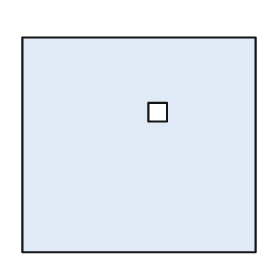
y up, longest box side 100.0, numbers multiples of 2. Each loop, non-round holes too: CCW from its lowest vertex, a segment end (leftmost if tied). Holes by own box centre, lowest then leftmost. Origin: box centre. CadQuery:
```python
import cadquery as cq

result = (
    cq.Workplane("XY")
    .moveTo(-50.0, -46.0)
    .lineTo(50.0, -46.0)
    .lineTo(50.0, 46.0)
    .lineTo(-50.0, 46.0)
    .close()
    .moveTo(4.0, 10.0)
    .lineTo(12.0, 10.0)
    .lineTo(12.0, 18.0)
    .lineTo(4.0, 18.0)
    .close()
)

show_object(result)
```